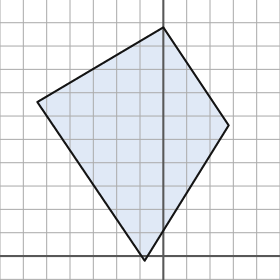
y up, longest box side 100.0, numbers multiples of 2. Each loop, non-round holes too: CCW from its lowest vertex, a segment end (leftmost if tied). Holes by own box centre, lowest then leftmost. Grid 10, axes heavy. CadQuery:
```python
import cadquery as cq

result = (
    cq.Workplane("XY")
    .moveTo(-8.0, -2.0)
    .lineTo(28.0, 56.0)
    .lineTo(0.0, 98.0)
    .lineTo(-54.0, 66.0)
    .close()
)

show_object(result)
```